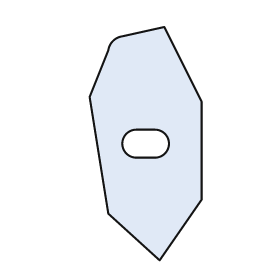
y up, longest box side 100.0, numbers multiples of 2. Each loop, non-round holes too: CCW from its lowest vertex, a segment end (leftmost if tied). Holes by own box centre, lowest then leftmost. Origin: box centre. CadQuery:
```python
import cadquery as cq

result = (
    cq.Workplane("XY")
    .moveTo(6.0, -50.0)
    .lineTo(24.0, -24.0)
    .lineTo(24.0, 18.0)
    .lineTo(8.0, 50.0)
    .lineTo(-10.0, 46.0)
    .threePointArc((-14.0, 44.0), (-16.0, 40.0))
    .lineTo(-24.0, 20.0)
    .lineTo(-16.0, -30.0)
    .close()
    .moveTo(-4.0, -6.0)
    .lineTo(4.0, -6.0)
    .threePointArc((10.0, 0.0), (4.0, 6.0))
    .lineTo(-4.0, 6.0)
    .threePointArc((-10.0, 0.0), (-4.0, -6.0))
    .close()
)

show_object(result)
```